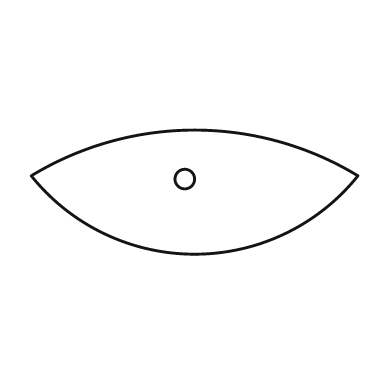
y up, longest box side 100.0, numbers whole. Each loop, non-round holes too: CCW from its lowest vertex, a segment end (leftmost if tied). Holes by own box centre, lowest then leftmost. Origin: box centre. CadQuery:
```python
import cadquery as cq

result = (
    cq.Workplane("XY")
    .moveTo(-50.0, 5.0)
    .threePointArc((0.0, -19.0), (50.0, 5.0))
    .threePointArc((0.0, 19.0), (-50.0, 5.0))
    .close()
    .moveTo(-3.0, 4.0)
    .circle(3.0)
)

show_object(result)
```